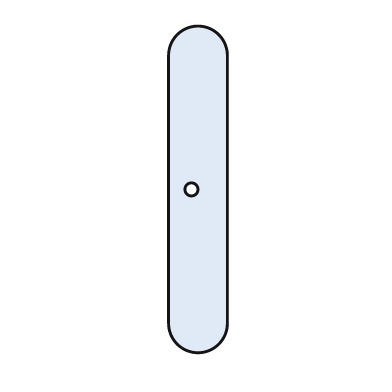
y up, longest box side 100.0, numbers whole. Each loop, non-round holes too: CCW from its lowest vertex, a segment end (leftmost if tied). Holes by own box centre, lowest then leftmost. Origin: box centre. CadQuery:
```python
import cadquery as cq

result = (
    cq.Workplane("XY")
    .moveTo(-9.0, -41.0)
    .threePointArc((0.0, -50.0), (9.0, -41.0))
    .lineTo(9.0, 41.0)
    .threePointArc((0.0, 50.0), (-9.0, 41.0))
    .close()
    .moveTo(-2.0, 0.0)
    .circle(2.0)
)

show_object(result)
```